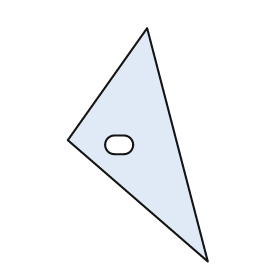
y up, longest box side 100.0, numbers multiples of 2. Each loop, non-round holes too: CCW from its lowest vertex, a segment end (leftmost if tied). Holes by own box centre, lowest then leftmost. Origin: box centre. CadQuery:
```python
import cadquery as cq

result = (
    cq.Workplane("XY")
    .moveTo(30.0, -50.0)
    .lineTo(4.0, 50.0)
    .lineTo(-30.0, 2.0)
    .close()
    .moveTo(-10.0, -4.0)
    .lineTo(-6.0, -4.0)
    .threePointArc((-2.0, 0.0), (-6.0, 4.0))
    .lineTo(-10.0, 4.0)
    .threePointArc((-14.0, 0.0), (-10.0, -4.0))
    .close()
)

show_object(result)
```